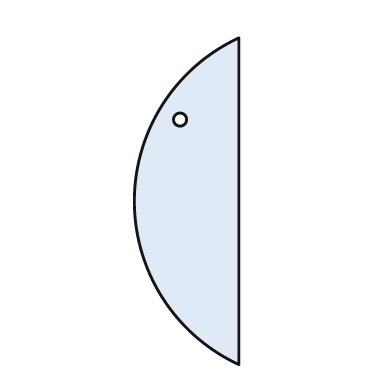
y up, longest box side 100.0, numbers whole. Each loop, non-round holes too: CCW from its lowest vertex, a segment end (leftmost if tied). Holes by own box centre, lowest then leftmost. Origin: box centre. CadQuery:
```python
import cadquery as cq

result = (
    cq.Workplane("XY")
    .moveTo(16.0, -50.0)
    .lineTo(16.0, 50.0)
    .threePointArc((-16.0, 0.0), (16.0, -50.0))
    .close()
    .moveTo(-2.0, 25.0)
    .circle(2.0)
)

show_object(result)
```